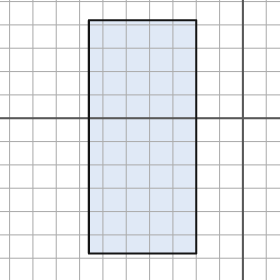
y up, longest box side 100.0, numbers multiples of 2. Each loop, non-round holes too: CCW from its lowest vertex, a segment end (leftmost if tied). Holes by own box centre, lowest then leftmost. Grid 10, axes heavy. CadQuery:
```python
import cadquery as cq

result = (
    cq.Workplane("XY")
    .moveTo(-66.0, -58.0)
    .lineTo(-20.0, -58.0)
    .lineTo(-20.0, 42.0)
    .lineTo(-66.0, 42.0)
    .close()
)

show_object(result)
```